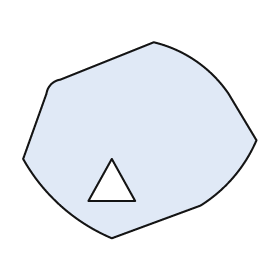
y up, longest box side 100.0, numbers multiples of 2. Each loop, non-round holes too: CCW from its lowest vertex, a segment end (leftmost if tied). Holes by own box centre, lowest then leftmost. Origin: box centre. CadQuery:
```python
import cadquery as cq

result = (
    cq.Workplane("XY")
    .moveTo(-12.0, -42.0)
    .lineTo(26.0, -28.0)
    .threePointArc((40.0, -16.0), (50.0, 0.0))
    .lineTo(38.0, 20.0)
    .threePointArc((24.0, 34.0), (6.0, 42.0))
    .lineTo(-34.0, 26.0)
    .threePointArc((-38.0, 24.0), (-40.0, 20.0))
    .lineTo(-50.0, -8.0)
    .threePointArc((-34.0, -28.0), (-12.0, -42.0))
    .close()
    .moveTo(-22.0, -26.0)
    .lineTo(-2.0, -26.0)
    .lineTo(-12.0, -8.0)
    .close()
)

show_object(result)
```